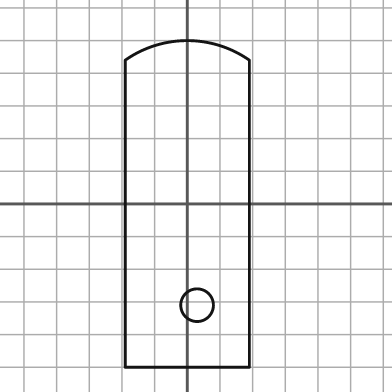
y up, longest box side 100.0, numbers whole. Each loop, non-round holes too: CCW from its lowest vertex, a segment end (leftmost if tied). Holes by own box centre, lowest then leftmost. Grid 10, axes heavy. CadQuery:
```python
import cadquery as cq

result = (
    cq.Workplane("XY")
    .moveTo(-19.0, -50.0)
    .lineTo(19.0, -50.0)
    .lineTo(19.0, 44.0)
    .threePointArc((0.0, 50.0), (-19.0, 44.0))
    .close()
    .moveTo(3.0, -31.0)
    .circle(5.0)
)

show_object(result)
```